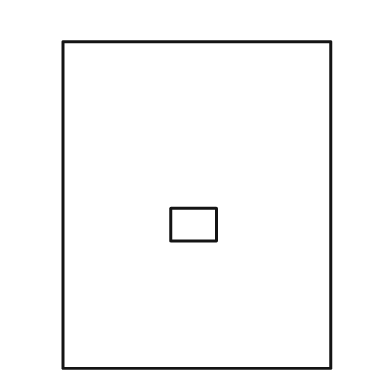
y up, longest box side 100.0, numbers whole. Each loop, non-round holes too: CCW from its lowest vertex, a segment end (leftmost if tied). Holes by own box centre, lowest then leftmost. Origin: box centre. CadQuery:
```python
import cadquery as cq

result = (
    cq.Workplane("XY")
    .moveTo(-41.0, -50.0)
    .lineTo(41.0, -50.0)
    .lineTo(41.0, 50.0)
    .lineTo(-41.0, 50.0)
    .close()
    .moveTo(-8.0, -11.0)
    .lineTo(6.0, -11.0)
    .lineTo(6.0, -1.0)
    .lineTo(-8.0, -1.0)
    .close()
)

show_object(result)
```